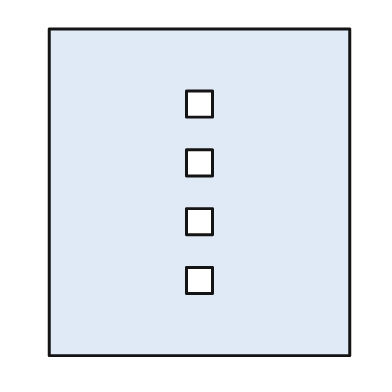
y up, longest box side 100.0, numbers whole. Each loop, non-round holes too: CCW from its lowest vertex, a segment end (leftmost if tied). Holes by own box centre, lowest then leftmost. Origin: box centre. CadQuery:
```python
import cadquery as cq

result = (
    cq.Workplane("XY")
    .moveTo(-46.0, -50.0)
    .lineTo(46.0, -50.0)
    .lineTo(46.0, 50.0)
    .lineTo(-46.0, 50.0)
    .close()
    .moveTo(-4.0, -31.0)
    .lineTo(4.0, -31.0)
    .lineTo(4.0, -23.0)
    .lineTo(-4.0, -23.0)
    .close()
    .moveTo(-4.0, -13.0)
    .lineTo(4.0, -13.0)
    .lineTo(4.0, -5.0)
    .lineTo(-4.0, -5.0)
    .close()
    .moveTo(-4.0, 5.0)
    .lineTo(4.0, 5.0)
    .lineTo(4.0, 13.0)
    .lineTo(-4.0, 13.0)
    .close()
    .moveTo(-4.0, 23.0)
    .lineTo(4.0, 23.0)
    .lineTo(4.0, 31.0)
    .lineTo(-4.0, 31.0)
    .close()
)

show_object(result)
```